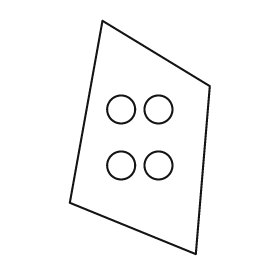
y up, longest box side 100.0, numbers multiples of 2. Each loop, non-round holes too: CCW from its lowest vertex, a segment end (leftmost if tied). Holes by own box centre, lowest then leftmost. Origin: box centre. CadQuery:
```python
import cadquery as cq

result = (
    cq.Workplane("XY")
    .moveTo(24.0, -50.0)
    .lineTo(30.0, 22.0)
    .lineTo(-16.0, 50.0)
    .lineTo(-30.0, -28.0)
    .close()
    .moveTo(-8.0, -12.0)
    .circle(6.0)
    .moveTo(8.0, -12.0)
    .circle(6.0)
    .moveTo(-8.0, 12.0)
    .circle(6.0)
    .moveTo(8.0, 12.0)
    .circle(6.0)
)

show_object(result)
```